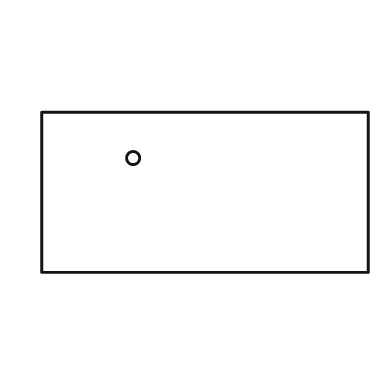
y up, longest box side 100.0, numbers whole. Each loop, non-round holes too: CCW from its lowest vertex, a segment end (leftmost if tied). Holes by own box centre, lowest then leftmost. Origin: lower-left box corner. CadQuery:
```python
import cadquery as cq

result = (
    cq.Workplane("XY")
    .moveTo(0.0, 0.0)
    .lineTo(100.0, 0.0)
    .lineTo(100.0, 49.0)
    .lineTo(0.0, 49.0)
    .close()
    .moveTo(28.0, 35.0)
    .circle(2.0)
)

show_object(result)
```